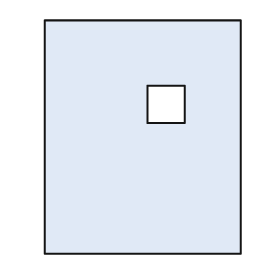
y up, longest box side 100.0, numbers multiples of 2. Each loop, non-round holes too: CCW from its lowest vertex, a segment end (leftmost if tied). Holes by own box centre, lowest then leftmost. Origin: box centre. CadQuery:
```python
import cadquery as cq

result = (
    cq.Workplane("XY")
    .moveTo(-42.0, -50.0)
    .lineTo(42.0, -50.0)
    .lineTo(42.0, 50.0)
    .lineTo(-42.0, 50.0)
    .close()
    .moveTo(2.0, 6.0)
    .lineTo(18.0, 6.0)
    .lineTo(18.0, 22.0)
    .lineTo(2.0, 22.0)
    .close()
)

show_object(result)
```